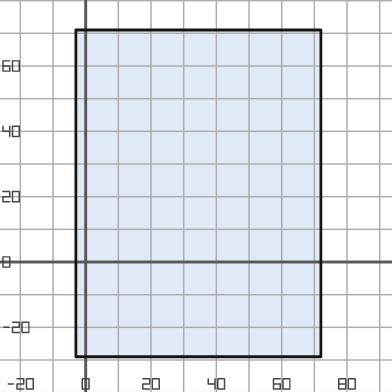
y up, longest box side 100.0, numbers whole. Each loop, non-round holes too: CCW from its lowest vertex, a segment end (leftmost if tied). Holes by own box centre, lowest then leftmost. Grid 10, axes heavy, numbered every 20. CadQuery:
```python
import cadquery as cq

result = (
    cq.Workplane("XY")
    .moveTo(-3.0, -29.0)
    .lineTo(72.0, -29.0)
    .lineTo(72.0, 71.0)
    .lineTo(-3.0, 71.0)
    .close()
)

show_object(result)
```